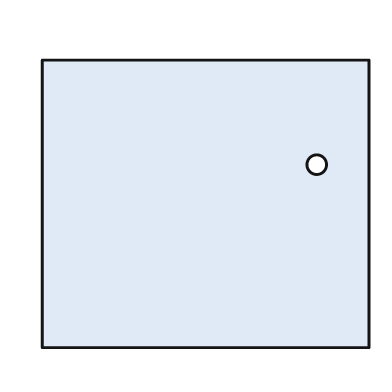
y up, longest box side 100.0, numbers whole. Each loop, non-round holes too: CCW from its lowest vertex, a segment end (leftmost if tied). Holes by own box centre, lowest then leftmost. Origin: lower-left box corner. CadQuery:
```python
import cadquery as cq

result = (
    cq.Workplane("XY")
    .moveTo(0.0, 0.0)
    .lineTo(100.0, 0.0)
    .lineTo(100.0, 88.0)
    .lineTo(0.0, 88.0)
    .close()
    .moveTo(84.0, 56.0)
    .circle(3.0)
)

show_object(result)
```